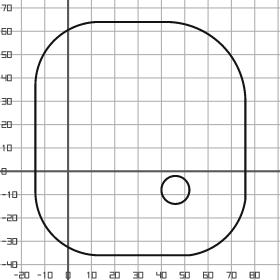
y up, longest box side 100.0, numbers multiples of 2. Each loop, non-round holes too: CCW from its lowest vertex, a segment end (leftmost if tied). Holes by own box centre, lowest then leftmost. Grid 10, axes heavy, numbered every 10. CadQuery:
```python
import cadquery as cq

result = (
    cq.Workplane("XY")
    .moveTo(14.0, -36.0)
    .lineTo(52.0, -36.0)
    .threePointArc((68.0, -28.0), (76.0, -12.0))
    .lineTo(76.0, 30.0)
    .threePointArc((66.0, 54.0), (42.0, 64.0))
    .lineTo(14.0, 64.0)
    .threePointArc((-6.0, 56.0), (-14.0, 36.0))
    .lineTo(-14.0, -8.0)
    .threePointArc((-6.0, -28.0), (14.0, -36.0))
    .close()
    .moveTo(46.0, -8.0)
    .circle(6.0)
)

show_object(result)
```